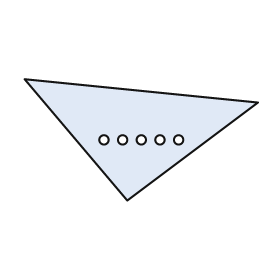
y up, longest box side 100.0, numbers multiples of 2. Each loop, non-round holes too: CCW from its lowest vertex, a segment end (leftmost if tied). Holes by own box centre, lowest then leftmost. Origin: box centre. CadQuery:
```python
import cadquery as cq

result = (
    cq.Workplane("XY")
    .moveTo(-6.0, -26.0)
    .lineTo(50.0, 16.0)
    .lineTo(-50.0, 26.0)
    .close()
    .moveTo(-16.0, 0.0)
    .circle(2.0)
    .moveTo(-8.0, 0.0)
    .circle(2.0)
    .moveTo(0.0, 0.0)
    .circle(2.0)
    .moveTo(8.0, 0.0)
    .circle(2.0)
    .moveTo(16.0, 0.0)
    .circle(2.0)
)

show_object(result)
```